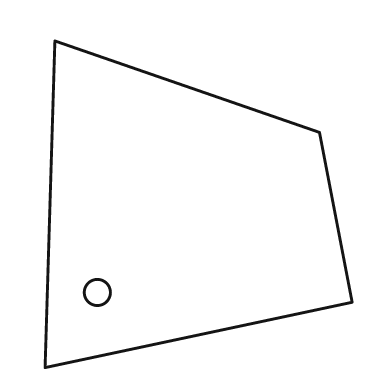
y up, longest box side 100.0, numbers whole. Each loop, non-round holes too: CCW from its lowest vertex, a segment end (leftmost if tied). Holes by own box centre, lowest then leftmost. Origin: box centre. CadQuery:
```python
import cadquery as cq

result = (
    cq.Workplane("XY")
    .moveTo(-47.0, -50.0)
    .lineTo(47.0, -30.0)
    .lineTo(37.0, 22.0)
    .lineTo(-44.0, 50.0)
    .close()
    .moveTo(-31.0, -27.0)
    .circle(4.0)
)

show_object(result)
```